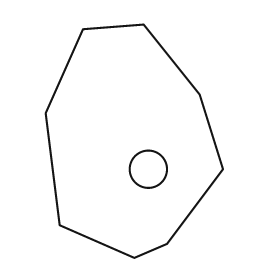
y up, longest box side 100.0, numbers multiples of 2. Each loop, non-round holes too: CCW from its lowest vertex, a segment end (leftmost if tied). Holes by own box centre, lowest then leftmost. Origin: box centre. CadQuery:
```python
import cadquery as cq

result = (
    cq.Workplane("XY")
    .moveTo(0.0, -50.0)
    .lineTo(14.0, -44.0)
    .lineTo(38.0, -12.0)
    .lineTo(28.0, 20.0)
    .lineTo(4.0, 50.0)
    .lineTo(-22.0, 48.0)
    .lineTo(-38.0, 12.0)
    .lineTo(-32.0, -36.0)
    .close()
    .moveTo(6.0, -12.0)
    .circle(8.0)
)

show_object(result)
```